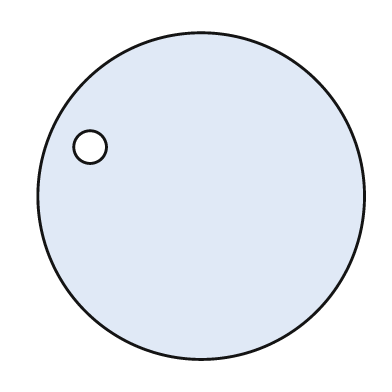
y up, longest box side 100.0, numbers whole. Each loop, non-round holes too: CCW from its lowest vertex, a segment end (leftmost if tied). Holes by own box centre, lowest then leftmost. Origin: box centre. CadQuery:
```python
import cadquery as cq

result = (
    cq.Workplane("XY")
    .moveTo(0.0, 0.0)
    .circle(50.0)
    .moveTo(-34.0, 15.0)
    .circle(5.0)
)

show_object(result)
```